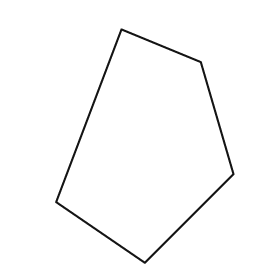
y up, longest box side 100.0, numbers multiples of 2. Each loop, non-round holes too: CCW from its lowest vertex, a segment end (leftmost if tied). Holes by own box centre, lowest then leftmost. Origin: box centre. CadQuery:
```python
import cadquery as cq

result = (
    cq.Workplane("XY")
    .moveTo(0.0, -50.0)
    .lineTo(38.0, -12.0)
    .lineTo(24.0, 36.0)
    .lineTo(-10.0, 50.0)
    .lineTo(-38.0, -24.0)
    .close()
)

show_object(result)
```